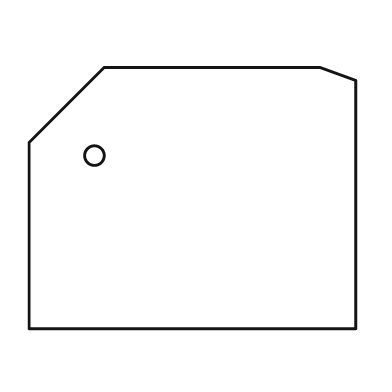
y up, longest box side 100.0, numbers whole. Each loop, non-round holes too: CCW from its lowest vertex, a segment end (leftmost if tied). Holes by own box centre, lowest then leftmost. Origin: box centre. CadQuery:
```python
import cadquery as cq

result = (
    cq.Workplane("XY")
    .moveTo(-50.0, -40.0)
    .lineTo(50.0, -40.0)
    .lineTo(50.0, 36.0)
    .lineTo(39.0, 40.0)
    .lineTo(-27.0, 40.0)
    .lineTo(-50.0, 17.0)
    .close()
    .moveTo(-30.0, 13.0)
    .circle(3.0)
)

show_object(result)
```